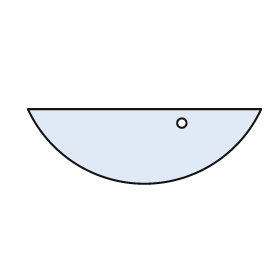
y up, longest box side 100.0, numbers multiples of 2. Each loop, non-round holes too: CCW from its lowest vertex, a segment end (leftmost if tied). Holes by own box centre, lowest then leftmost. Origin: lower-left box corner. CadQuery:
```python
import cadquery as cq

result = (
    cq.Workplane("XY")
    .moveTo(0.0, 32.0)
    .threePointArc((50.0, 0.0), (100.0, 32.0))
    .close()
    .moveTo(66.0, 26.0)
    .circle(2.0)
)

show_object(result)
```